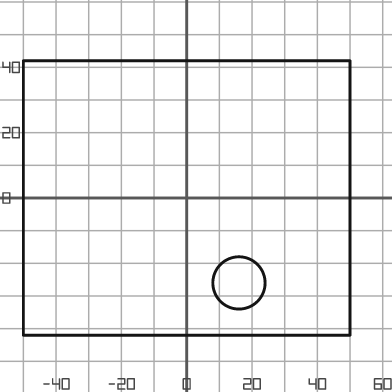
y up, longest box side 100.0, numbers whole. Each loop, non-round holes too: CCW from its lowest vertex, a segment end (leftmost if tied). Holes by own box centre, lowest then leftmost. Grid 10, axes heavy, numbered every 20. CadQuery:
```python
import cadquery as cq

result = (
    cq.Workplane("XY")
    .moveTo(-50.0, -42.0)
    .lineTo(50.0, -42.0)
    .lineTo(50.0, 42.0)
    .lineTo(-50.0, 42.0)
    .close()
    .moveTo(16.0, -26.0)
    .circle(8.0)
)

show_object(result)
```